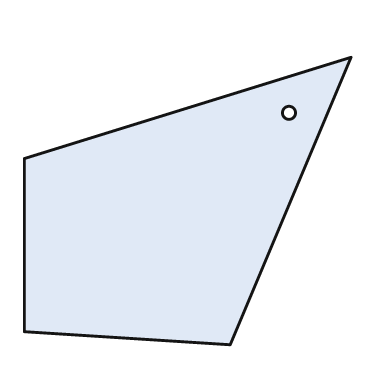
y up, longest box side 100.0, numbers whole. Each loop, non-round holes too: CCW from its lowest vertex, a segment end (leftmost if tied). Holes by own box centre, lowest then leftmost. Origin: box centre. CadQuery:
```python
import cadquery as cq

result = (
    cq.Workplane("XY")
    .moveTo(13.0, -44.0)
    .lineTo(50.0, 44.0)
    .lineTo(-50.0, 13.0)
    .lineTo(-50.0, -40.0)
    .close()
    .moveTo(31.0, 27.0)
    .circle(2.0)
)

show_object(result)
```